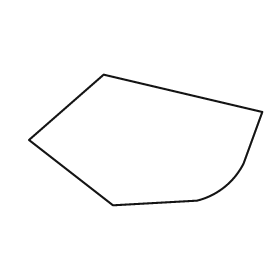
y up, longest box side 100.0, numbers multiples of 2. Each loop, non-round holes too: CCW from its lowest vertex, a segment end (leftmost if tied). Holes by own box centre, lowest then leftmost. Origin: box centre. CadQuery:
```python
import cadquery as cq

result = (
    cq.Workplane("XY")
    .moveTo(-14.0, -28.0)
    .lineTo(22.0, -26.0)
    .threePointArc((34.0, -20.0), (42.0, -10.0))
    .lineTo(50.0, 12.0)
    .lineTo(-18.0, 28.0)
    .lineTo(-50.0, 0.0)
    .close()
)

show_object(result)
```